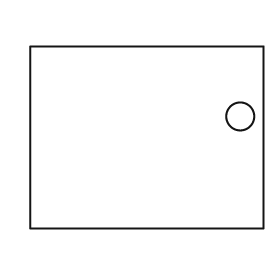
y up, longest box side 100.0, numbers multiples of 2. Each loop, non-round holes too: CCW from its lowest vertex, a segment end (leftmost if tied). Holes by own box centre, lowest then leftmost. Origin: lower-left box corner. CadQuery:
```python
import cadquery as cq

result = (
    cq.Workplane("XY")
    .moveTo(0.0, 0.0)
    .lineTo(100.0, 0.0)
    .lineTo(100.0, 78.0)
    .lineTo(0.0, 78.0)
    .close()
    .moveTo(90.0, 48.0)
    .circle(6.0)
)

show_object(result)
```